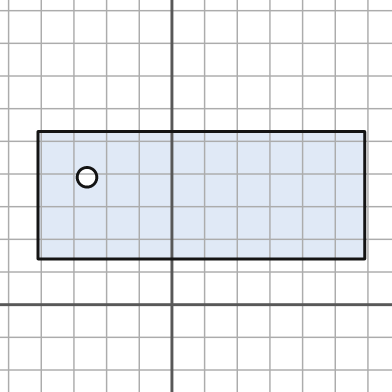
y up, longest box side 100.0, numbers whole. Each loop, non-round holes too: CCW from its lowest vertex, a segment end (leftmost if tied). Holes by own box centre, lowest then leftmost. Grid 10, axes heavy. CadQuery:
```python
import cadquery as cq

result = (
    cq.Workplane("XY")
    .moveTo(-41.0, 14.0)
    .lineTo(59.0, 14.0)
    .lineTo(59.0, 53.0)
    .lineTo(-41.0, 53.0)
    .close()
    .moveTo(-26.0, 39.0)
    .circle(3.0)
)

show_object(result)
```